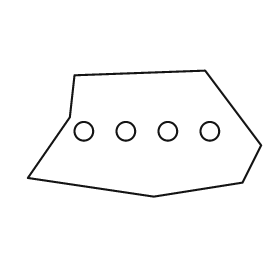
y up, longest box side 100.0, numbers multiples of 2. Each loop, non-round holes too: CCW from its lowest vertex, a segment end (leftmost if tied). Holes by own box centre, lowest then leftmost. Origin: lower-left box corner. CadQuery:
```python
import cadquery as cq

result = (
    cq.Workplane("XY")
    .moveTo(54.0, 0.0)
    .lineTo(92.0, 6.0)
    .lineTo(100.0, 22.0)
    .lineTo(76.0, 54.0)
    .lineTo(20.0, 52.0)
    .lineTo(18.0, 34.0)
    .lineTo(0.0, 8.0)
    .close()
    .moveTo(24.0, 28.0)
    .circle(4.0)
    .moveTo(42.0, 28.0)
    .circle(4.0)
    .moveTo(60.0, 28.0)
    .circle(4.0)
    .moveTo(78.0, 28.0)
    .circle(4.0)
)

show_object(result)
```